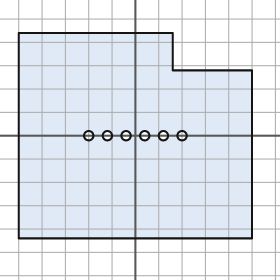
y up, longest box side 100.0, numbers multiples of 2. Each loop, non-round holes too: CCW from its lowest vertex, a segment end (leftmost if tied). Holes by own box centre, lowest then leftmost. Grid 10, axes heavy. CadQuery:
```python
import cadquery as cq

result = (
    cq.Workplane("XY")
    .moveTo(-50.0, -44.0)
    .lineTo(50.0, -44.0)
    .lineTo(50.0, 28.0)
    .lineTo(16.0, 28.0)
    .lineTo(16.0, 44.0)
    .lineTo(-50.0, 44.0)
    .close()
    .moveTo(-20.0, 0.0)
    .circle(2.0)
    .moveTo(-12.0, 0.0)
    .circle(2.0)
    .moveTo(-4.0, 0.0)
    .circle(2.0)
    .moveTo(4.0, 0.0)
    .circle(2.0)
    .moveTo(12.0, 0.0)
    .circle(2.0)
    .moveTo(20.0, 0.0)
    .circle(2.0)
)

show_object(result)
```